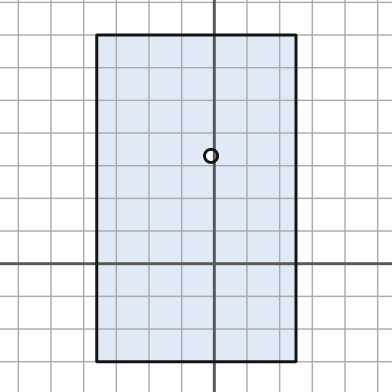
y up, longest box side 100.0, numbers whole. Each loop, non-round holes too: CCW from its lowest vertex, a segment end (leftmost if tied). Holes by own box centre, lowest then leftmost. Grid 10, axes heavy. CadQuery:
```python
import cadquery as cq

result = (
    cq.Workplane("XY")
    .moveTo(-36.0, -30.0)
    .lineTo(25.0, -30.0)
    .lineTo(25.0, 70.0)
    .lineTo(-36.0, 70.0)
    .close()
    .moveTo(-1.0, 33.0)
    .circle(2.0)
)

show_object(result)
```